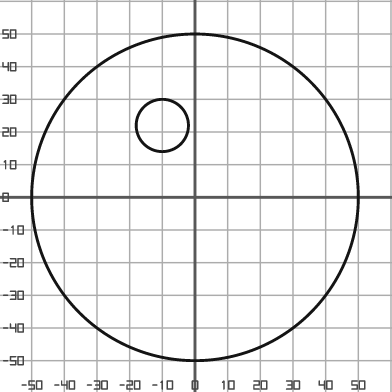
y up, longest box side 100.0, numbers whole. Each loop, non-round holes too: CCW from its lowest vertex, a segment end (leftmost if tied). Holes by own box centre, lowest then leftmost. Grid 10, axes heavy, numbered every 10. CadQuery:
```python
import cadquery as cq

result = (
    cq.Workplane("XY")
    .moveTo(0.0, 0.0)
    .circle(50.0)
    .moveTo(-10.0, 22.0)
    .circle(8.0)
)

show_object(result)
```